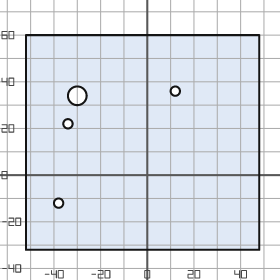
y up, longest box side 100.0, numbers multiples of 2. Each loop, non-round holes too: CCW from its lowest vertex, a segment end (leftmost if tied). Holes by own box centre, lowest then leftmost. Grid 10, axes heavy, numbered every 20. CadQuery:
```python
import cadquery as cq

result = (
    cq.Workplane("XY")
    .moveTo(-52.0, -32.0)
    .lineTo(48.0, -32.0)
    .lineTo(48.0, 60.0)
    .lineTo(-52.0, 60.0)
    .close()
    .moveTo(-38.0, -12.0)
    .circle(2.0)
    .moveTo(-34.0, 22.0)
    .circle(2.0)
    .moveTo(-30.0, 34.0)
    .circle(4.0)
    .moveTo(12.0, 36.0)
    .circle(2.0)
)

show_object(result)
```